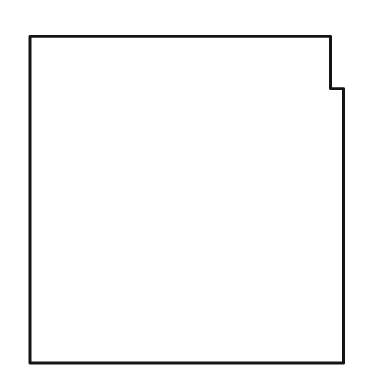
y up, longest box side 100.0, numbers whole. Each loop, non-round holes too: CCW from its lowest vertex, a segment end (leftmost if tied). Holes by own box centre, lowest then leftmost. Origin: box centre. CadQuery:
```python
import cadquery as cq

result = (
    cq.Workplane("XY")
    .moveTo(-48.0, -50.0)
    .lineTo(48.0, -50.0)
    .lineTo(48.0, 34.0)
    .lineTo(44.0, 34.0)
    .lineTo(44.0, 50.0)
    .lineTo(-48.0, 50.0)
    .close()
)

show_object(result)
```